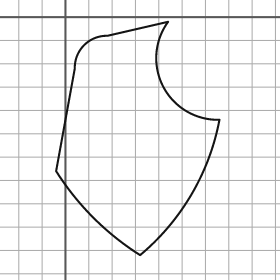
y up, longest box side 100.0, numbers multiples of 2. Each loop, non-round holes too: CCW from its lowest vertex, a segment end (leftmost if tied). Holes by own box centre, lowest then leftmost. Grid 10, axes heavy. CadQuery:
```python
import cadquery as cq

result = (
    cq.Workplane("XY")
    .moveTo(32.0, -102.0)
    .threePointArc((54.0, -76.0), (66.0, -44.0))
    .threePointArc((42.0, -30.0), (44.0, -2.0))
    .lineTo(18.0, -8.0)
    .threePointArc((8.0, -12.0), (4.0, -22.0))
    .lineTo(-4.0, -66.0)
    .threePointArc((12.0, -86.0), (32.0, -102.0))
    .close()
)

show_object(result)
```